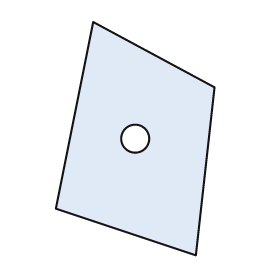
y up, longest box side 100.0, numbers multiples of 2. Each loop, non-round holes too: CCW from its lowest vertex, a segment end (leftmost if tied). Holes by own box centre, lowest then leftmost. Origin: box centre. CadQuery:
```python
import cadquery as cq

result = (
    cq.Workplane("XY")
    .moveTo(26.0, -50.0)
    .lineTo(34.0, 22.0)
    .lineTo(-18.0, 50.0)
    .lineTo(-34.0, -30.0)
    .close()
    .moveTo(0.0, 0.0)
    .circle(6.0)
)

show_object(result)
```